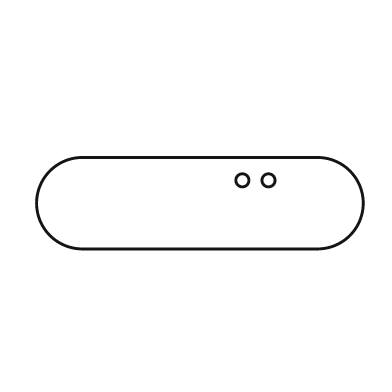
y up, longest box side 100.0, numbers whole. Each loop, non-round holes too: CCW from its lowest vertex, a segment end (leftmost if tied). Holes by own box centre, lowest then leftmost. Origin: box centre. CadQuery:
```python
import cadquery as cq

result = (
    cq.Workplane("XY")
    .moveTo(-36.0, -14.0)
    .lineTo(36.0, -14.0)
    .threePointArc((50.0, 0.0), (36.0, 14.0))
    .lineTo(-36.0, 14.0)
    .threePointArc((-50.0, 0.0), (-36.0, -14.0))
    .close()
    .moveTo(13.0, 7.0)
    .circle(2.0)
    .moveTo(21.0, 7.0)
    .circle(2.0)
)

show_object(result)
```